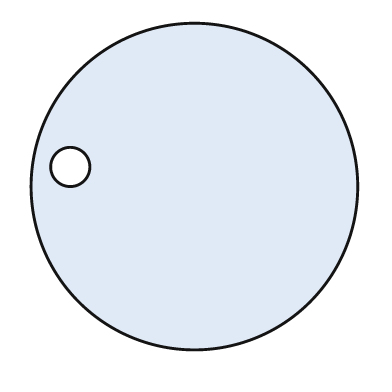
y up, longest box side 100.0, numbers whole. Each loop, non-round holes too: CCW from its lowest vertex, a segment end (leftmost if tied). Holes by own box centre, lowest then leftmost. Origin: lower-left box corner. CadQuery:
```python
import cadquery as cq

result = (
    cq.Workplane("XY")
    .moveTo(50.0, 50.0)
    .circle(50.0)
    .moveTo(12.0, 56.0)
    .circle(6.0)
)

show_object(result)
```